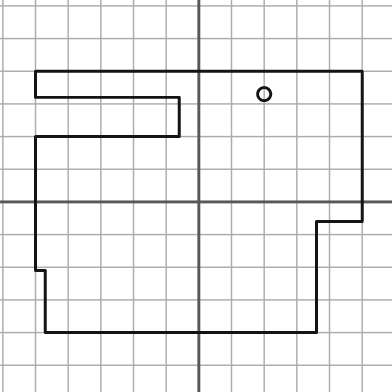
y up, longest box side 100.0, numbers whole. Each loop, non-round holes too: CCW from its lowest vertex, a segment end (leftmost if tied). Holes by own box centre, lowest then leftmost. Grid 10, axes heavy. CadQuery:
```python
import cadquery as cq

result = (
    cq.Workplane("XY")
    .moveTo(-47.0, -40.0)
    .lineTo(36.0, -40.0)
    .lineTo(36.0, -6.0)
    .lineTo(50.0, -6.0)
    .lineTo(50.0, 40.0)
    .lineTo(-50.0, 40.0)
    .lineTo(-50.0, 32.0)
    .lineTo(-6.0, 32.0)
    .lineTo(-6.0, 20.0)
    .lineTo(-50.0, 20.0)
    .lineTo(-50.0, -21.0)
    .lineTo(-47.0, -21.0)
    .close()
    .moveTo(20.0, 33.0)
    .circle(2.0)
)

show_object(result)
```